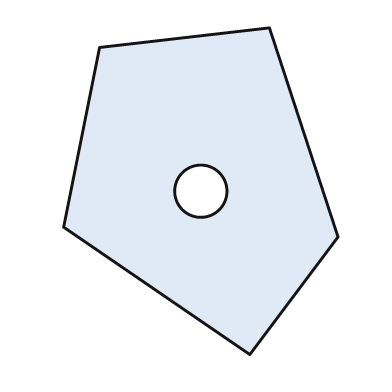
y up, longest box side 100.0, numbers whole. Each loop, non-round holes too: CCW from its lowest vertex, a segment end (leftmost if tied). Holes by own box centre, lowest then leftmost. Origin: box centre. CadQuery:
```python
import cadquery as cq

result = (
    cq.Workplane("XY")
    .moveTo(15.0, -50.0)
    .lineTo(42.0, -14.0)
    .lineTo(21.0, 50.0)
    .lineTo(-31.0, 44.0)
    .lineTo(-42.0, -11.0)
    .close()
    .moveTo(0.0, 0.0)
    .circle(8.0)
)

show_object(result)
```